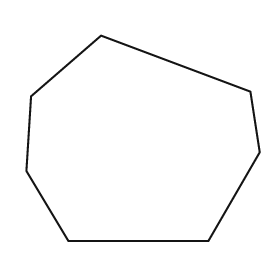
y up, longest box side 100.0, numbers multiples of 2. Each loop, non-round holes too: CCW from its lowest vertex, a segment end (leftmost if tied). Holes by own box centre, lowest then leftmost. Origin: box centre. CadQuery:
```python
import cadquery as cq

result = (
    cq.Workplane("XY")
    .moveTo(-32.0, -44.0)
    .lineTo(28.0, -44.0)
    .lineTo(50.0, -6.0)
    .lineTo(46.0, 20.0)
    .lineTo(-18.0, 44.0)
    .lineTo(-48.0, 18.0)
    .lineTo(-50.0, -14.0)
    .close()
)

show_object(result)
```